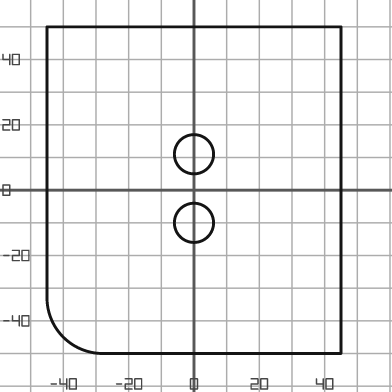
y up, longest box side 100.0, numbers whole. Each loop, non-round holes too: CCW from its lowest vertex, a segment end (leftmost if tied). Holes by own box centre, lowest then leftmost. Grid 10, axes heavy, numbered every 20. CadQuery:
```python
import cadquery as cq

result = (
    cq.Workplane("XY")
    .moveTo(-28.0, -50.0)
    .lineTo(45.0, -50.0)
    .lineTo(45.0, 50.0)
    .lineTo(-45.0, 50.0)
    .lineTo(-45.0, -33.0)
    .threePointArc((-40.0, -45.0), (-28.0, -50.0))
    .close()
    .moveTo(0.0, -10.0)
    .circle(6.0)
    .moveTo(0.0, 11.0)
    .circle(6.0)
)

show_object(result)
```